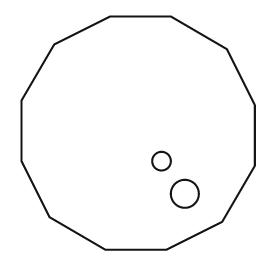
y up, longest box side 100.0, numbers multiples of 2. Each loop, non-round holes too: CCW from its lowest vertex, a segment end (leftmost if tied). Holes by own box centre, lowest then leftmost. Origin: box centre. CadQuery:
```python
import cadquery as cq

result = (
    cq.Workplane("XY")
    .moveTo(-14.0, -50.0)
    .lineTo(12.0, -50.0)
    .lineTo(36.0, -38.0)
    .lineTo(50.0, -14.0)
    .lineTo(50.0, 12.0)
    .lineTo(38.0, 36.0)
    .lineTo(14.0, 50.0)
    .lineTo(-12.0, 50.0)
    .lineTo(-36.0, 38.0)
    .lineTo(-50.0, 14.0)
    .lineTo(-50.0, -12.0)
    .lineTo(-38.0, -36.0)
    .close()
    .moveTo(20.0, -26.0)
    .circle(6.0)
    .moveTo(10.0, -12.0)
    .circle(4.0)
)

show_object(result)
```